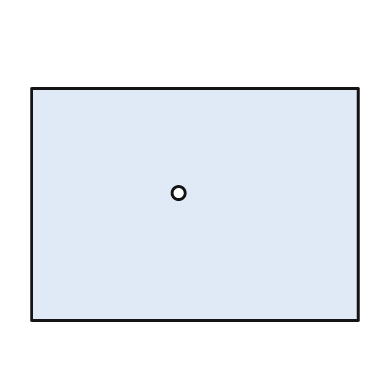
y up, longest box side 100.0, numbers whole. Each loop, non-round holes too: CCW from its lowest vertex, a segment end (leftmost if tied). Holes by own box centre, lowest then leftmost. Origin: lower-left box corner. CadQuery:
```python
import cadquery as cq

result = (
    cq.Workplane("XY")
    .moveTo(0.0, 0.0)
    .lineTo(100.0, 0.0)
    .lineTo(100.0, 71.0)
    .lineTo(0.0, 71.0)
    .close()
    .moveTo(45.0, 39.0)
    .circle(2.0)
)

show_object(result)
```